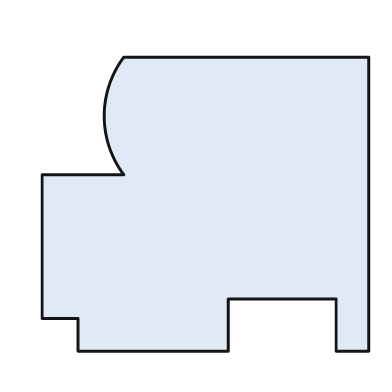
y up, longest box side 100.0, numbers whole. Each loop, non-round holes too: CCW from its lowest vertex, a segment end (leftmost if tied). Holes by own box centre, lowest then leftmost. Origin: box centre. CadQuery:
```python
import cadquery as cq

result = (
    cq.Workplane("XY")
    .moveTo(-39.0, -45.0)
    .lineTo(7.0, -45.0)
    .lineTo(7.0, -29.0)
    .lineTo(40.0, -29.0)
    .lineTo(40.0, -45.0)
    .lineTo(50.0, -45.0)
    .lineTo(50.0, 45.0)
    .lineTo(-25.0, 45.0)
    .threePointArc((-31.0, 27.0), (-25.0, 9.0))
    .lineTo(-50.0, 9.0)
    .lineTo(-50.0, -35.0)
    .lineTo(-39.0, -35.0)
    .close()
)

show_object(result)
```